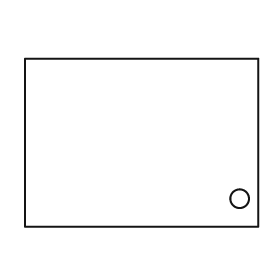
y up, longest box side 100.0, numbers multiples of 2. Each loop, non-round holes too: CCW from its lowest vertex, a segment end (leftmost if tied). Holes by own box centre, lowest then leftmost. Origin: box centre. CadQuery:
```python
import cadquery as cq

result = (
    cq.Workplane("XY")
    .moveTo(-50.0, -36.0)
    .lineTo(50.0, -36.0)
    .lineTo(50.0, 36.0)
    .lineTo(-50.0, 36.0)
    .close()
    .moveTo(42.0, -24.0)
    .circle(4.0)
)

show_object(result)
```